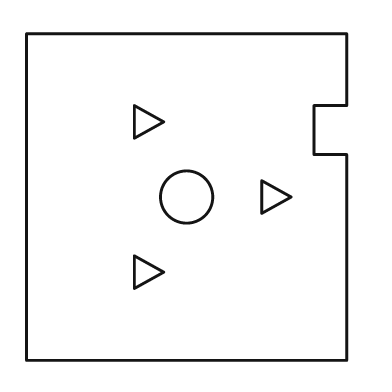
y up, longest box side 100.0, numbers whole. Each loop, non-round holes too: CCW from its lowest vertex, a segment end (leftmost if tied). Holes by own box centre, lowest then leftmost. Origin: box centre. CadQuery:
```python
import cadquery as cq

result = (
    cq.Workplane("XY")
    .moveTo(-49.0, -50.0)
    .lineTo(49.0, -50.0)
    .lineTo(49.0, 13.0)
    .lineTo(39.0, 13.0)
    .lineTo(39.0, 28.0)
    .lineTo(49.0, 28.0)
    .lineTo(49.0, 50.0)
    .lineTo(-49.0, 50.0)
    .close()
    .moveTo(-16.0, -28.0)
    .lineTo(-7.0, -23.0)
    .lineTo(-16.0, -18.0)
    .close()
    .moveTo(0.0, 0.0)
    .circle(8.0)
    .moveTo(23.0, -5.0)
    .lineTo(32.0, 0.0)
    .lineTo(23.0, 5.0)
    .close()
    .moveTo(-16.0, 18.0)
    .lineTo(-7.0, 23.0)
    .lineTo(-16.0, 28.0)
    .close()
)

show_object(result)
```